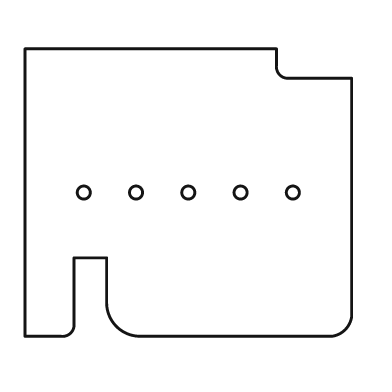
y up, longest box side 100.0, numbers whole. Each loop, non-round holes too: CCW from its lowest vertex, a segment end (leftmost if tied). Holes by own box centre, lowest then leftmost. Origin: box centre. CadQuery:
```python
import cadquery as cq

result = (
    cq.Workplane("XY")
    .moveTo(-50.0, -44.0)
    .lineTo(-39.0, -44.0)
    .threePointArc((-36.0, -43.0), (-35.0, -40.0))
    .lineTo(-35.0, -20.0)
    .lineTo(-25.0, -20.0)
    .lineTo(-25.0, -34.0)
    .threePointArc((-22.0, -41.0), (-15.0, -44.0))
    .lineTo(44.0, -44.0)
    .threePointArc((48.0, -42.0), (50.0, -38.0))
    .lineTo(50.0, 35.0)
    .lineTo(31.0, 35.0)
    .threePointArc((28.0, 36.0), (27.0, 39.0))
    .lineTo(27.0, 44.0)
    .lineTo(-50.0, 44.0)
    .close()
    .moveTo(-32.0, 0.0)
    .circle(2.0)
    .moveTo(-16.0, 0.0)
    .circle(2.0)
    .moveTo(0.0, 0.0)
    .circle(2.0)
    .moveTo(16.0, 0.0)
    .circle(2.0)
    .moveTo(32.0, 0.0)
    .circle(2.0)
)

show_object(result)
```